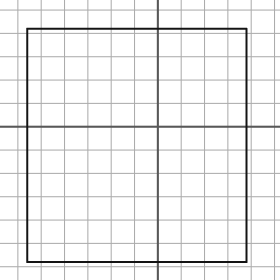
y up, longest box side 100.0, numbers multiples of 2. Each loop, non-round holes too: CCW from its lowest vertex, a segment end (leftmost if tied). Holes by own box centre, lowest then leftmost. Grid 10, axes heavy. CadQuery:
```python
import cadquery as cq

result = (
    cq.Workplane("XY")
    .moveTo(-56.0, -58.0)
    .lineTo(38.0, -58.0)
    .lineTo(38.0, 42.0)
    .lineTo(-56.0, 42.0)
    .close()
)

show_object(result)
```